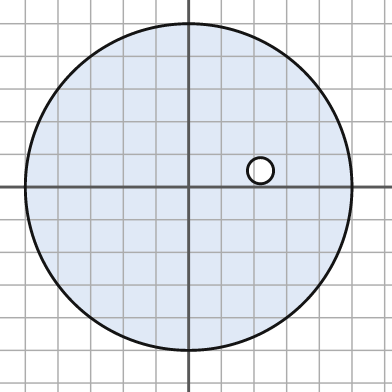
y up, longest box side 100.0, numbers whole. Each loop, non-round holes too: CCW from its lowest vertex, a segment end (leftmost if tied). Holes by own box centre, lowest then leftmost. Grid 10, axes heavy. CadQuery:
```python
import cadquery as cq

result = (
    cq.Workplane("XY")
    .moveTo(0.0, 0.0)
    .circle(50.0)
    .moveTo(22.0, 5.0)
    .circle(4.0)
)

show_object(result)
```